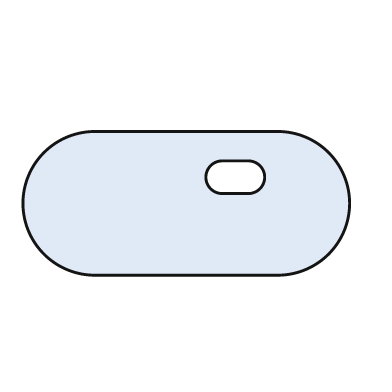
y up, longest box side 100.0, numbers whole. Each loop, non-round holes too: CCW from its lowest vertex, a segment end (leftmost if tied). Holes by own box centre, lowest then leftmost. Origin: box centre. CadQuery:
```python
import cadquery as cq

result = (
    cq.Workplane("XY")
    .moveTo(-28.0, -22.0)
    .lineTo(28.0, -22.0)
    .threePointArc((50.0, 0.0), (28.0, 22.0))
    .lineTo(-28.0, 22.0)
    .threePointArc((-50.0, 0.0), (-28.0, -22.0))
    .close()
    .moveTo(11.0, 3.0)
    .lineTo(19.0, 3.0)
    .threePointArc((24.0, 8.0), (19.0, 13.0))
    .lineTo(11.0, 13.0)
    .threePointArc((6.0, 8.0), (11.0, 3.0))
    .close()
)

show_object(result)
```